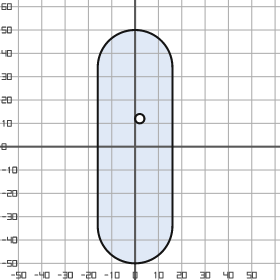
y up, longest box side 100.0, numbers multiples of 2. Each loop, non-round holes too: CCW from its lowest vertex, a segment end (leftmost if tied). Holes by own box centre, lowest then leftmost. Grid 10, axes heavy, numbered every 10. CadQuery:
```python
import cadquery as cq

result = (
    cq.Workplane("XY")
    .moveTo(-16.0, -34.0)
    .threePointArc((0.0, -50.0), (16.0, -34.0))
    .lineTo(16.0, 34.0)
    .threePointArc((0.0, 50.0), (-16.0, 34.0))
    .close()
    .moveTo(2.0, 12.0)
    .circle(2.0)
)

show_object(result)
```